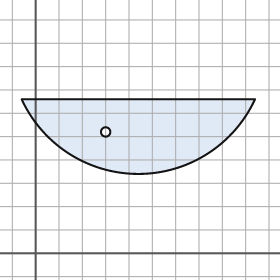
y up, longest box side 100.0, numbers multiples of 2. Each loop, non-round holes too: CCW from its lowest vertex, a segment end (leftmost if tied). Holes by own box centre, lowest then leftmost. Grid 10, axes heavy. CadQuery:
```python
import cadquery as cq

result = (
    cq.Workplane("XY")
    .moveTo(-6.0, 66.0)
    .threePointArc((44.0, 34.0), (94.0, 66.0))
    .close()
    .moveTo(30.0, 52.0)
    .circle(2.0)
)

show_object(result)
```